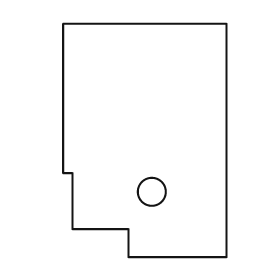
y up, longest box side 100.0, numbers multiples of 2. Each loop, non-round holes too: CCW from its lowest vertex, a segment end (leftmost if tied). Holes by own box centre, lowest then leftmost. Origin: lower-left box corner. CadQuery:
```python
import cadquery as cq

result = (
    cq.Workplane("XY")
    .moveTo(28.0, 0.0)
    .lineTo(70.0, 0.0)
    .lineTo(70.0, 100.0)
    .lineTo(0.0, 100.0)
    .lineTo(0.0, 36.0)
    .lineTo(4.0, 36.0)
    .lineTo(4.0, 12.0)
    .lineTo(28.0, 12.0)
    .close()
    .moveTo(38.0, 28.0)
    .circle(6.0)
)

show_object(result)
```